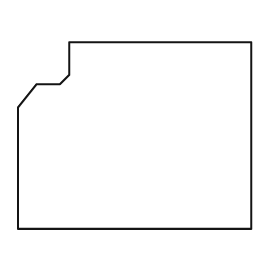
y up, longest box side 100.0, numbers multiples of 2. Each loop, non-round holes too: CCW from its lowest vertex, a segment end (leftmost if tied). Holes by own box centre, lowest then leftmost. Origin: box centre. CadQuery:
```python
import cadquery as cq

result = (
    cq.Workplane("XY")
    .moveTo(-50.0, -40.0)
    .lineTo(50.0, -40.0)
    .lineTo(50.0, 40.0)
    .lineTo(-28.0, 40.0)
    .lineTo(-28.0, 26.0)
    .lineTo(-32.0, 22.0)
    .lineTo(-42.0, 22.0)
    .lineTo(-50.0, 12.0)
    .close()
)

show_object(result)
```